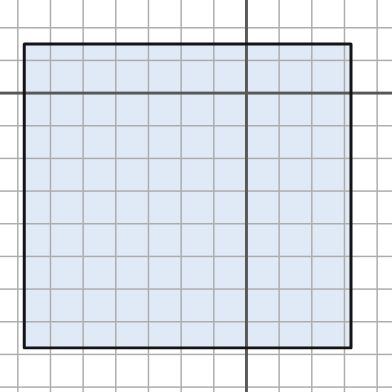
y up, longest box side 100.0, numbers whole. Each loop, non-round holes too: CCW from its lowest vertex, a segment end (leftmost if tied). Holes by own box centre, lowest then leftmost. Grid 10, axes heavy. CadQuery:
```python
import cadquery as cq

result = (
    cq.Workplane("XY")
    .moveTo(-68.0, -78.0)
    .lineTo(32.0, -78.0)
    .lineTo(32.0, 15.0)
    .lineTo(-68.0, 15.0)
    .close()
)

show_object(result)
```